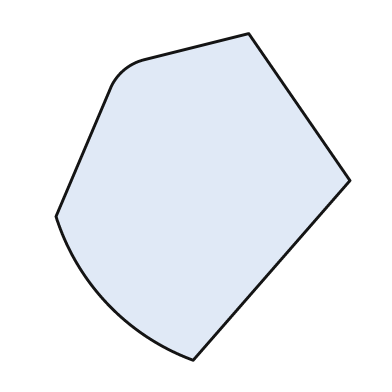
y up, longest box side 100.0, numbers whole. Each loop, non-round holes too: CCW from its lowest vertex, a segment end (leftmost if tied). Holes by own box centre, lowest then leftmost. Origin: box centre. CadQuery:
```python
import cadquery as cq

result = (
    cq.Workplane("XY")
    .moveTo(-3.0, -50.0)
    .lineTo(45.0, 5.0)
    .lineTo(14.0, 50.0)
    .lineTo(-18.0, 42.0)
    .threePointArc((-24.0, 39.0), (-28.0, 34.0))
    .lineTo(-45.0, -6.0)
    .threePointArc((-29.0, -33.0), (-3.0, -50.0))
    .close()
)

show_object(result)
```